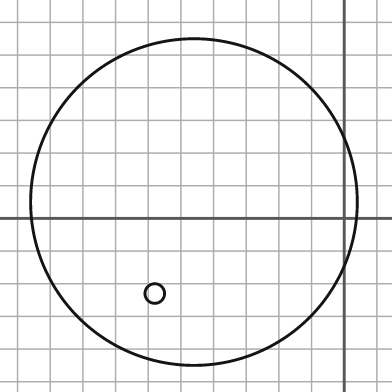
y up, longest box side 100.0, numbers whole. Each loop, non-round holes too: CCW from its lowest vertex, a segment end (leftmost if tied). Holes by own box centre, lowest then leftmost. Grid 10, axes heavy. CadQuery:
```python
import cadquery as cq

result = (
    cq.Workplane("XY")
    .moveTo(-46.0, 5.0)
    .circle(50.0)
    .moveTo(-58.0, -23.0)
    .circle(3.0)
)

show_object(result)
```